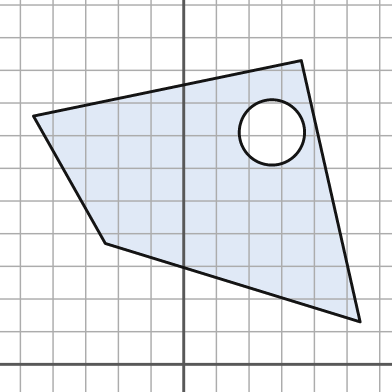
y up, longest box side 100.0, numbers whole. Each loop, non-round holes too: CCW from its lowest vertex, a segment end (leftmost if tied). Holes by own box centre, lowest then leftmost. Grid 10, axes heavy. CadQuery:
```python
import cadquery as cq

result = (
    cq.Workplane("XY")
    .moveTo(54.0, 13.0)
    .lineTo(36.0, 93.0)
    .lineTo(-46.0, 76.0)
    .lineTo(-24.0, 37.0)
    .close()
    .moveTo(27.0, 71.0)
    .circle(10.0)
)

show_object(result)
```